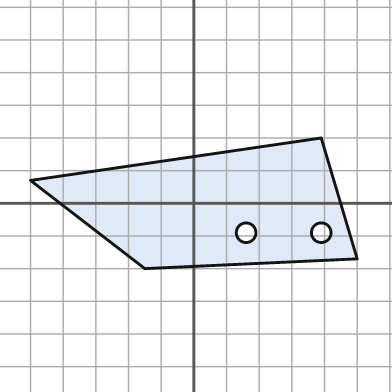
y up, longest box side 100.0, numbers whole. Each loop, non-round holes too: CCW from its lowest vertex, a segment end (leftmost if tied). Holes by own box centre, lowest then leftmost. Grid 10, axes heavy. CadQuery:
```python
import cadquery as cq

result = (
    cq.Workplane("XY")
    .moveTo(-15.0, -20.0)
    .lineTo(50.0, -17.0)
    .lineTo(39.0, 20.0)
    .lineTo(-50.0, 7.0)
    .close()
    .moveTo(16.0, -9.0)
    .circle(3.0)
    .moveTo(39.0, -9.0)
    .circle(3.0)
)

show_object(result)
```